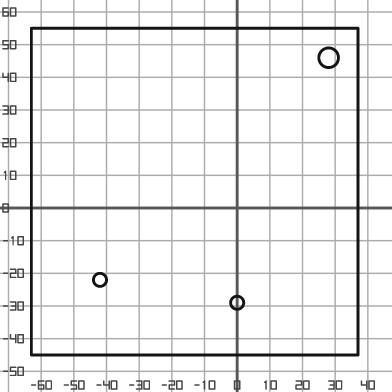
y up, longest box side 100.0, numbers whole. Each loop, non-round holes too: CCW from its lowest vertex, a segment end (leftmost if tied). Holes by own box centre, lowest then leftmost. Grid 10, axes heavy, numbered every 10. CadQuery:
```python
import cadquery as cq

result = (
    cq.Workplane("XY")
    .moveTo(-63.0, -45.0)
    .lineTo(37.0, -45.0)
    .lineTo(37.0, 55.0)
    .lineTo(-63.0, 55.0)
    .close()
    .moveTo(0.0, -29.0)
    .circle(2.0)
    .moveTo(-42.0, -22.0)
    .circle(2.0)
    .moveTo(28.0, 46.0)
    .circle(3.0)
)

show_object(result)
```